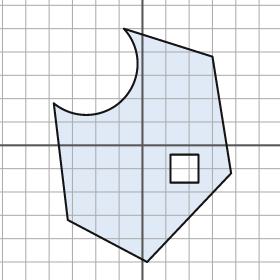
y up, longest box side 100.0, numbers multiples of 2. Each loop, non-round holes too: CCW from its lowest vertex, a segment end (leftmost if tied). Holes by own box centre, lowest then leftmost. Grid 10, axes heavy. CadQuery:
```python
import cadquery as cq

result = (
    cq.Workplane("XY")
    .moveTo(2.0, -50.0)
    .lineTo(38.0, -12.0)
    .lineTo(30.0, 38.0)
    .lineTo(-8.0, 50.0)
    .threePointArc((-8.0, 20.0), (-38.0, 18.0))
    .lineTo(-32.0, -32.0)
    .close()
    .moveTo(12.0, -16.0)
    .lineTo(24.0, -16.0)
    .lineTo(24.0, -4.0)
    .lineTo(12.0, -4.0)
    .close()
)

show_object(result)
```